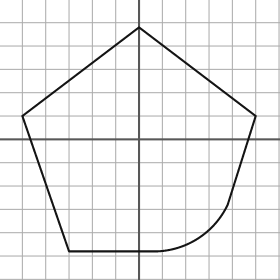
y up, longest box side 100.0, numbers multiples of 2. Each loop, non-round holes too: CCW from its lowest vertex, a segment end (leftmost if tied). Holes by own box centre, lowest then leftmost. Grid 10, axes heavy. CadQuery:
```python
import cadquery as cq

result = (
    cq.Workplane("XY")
    .moveTo(-30.0, -48.0)
    .lineTo(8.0, -48.0)
    .threePointArc((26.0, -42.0), (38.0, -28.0))
    .lineTo(50.0, 10.0)
    .lineTo(0.0, 48.0)
    .lineTo(-50.0, 10.0)
    .close()
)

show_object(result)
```